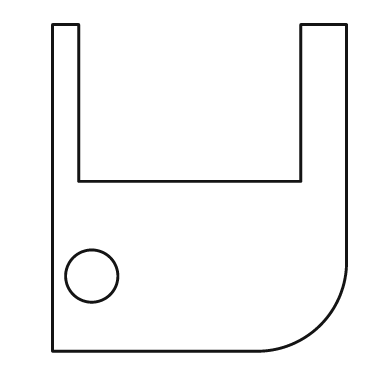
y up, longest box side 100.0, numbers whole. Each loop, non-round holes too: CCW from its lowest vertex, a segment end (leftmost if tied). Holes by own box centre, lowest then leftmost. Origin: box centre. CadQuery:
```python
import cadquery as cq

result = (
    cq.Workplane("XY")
    .moveTo(-45.0, -50.0)
    .lineTo(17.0, -50.0)
    .threePointArc((37.0, -42.0), (45.0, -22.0))
    .lineTo(45.0, 50.0)
    .lineTo(31.0, 50.0)
    .lineTo(31.0, 2.0)
    .lineTo(-37.0, 2.0)
    .lineTo(-37.0, 50.0)
    .lineTo(-45.0, 50.0)
    .close()
    .moveTo(-33.0, -27.0)
    .circle(8.0)
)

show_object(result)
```